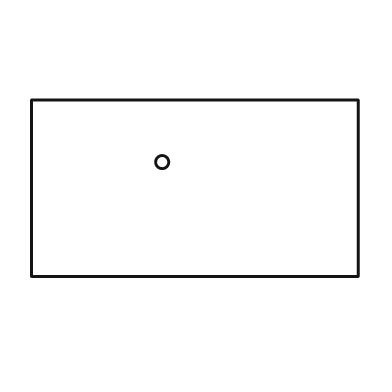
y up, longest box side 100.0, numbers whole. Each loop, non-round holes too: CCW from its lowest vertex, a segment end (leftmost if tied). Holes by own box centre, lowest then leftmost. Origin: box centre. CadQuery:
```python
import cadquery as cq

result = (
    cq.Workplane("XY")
    .moveTo(-50.0, -27.0)
    .lineTo(50.0, -27.0)
    .lineTo(50.0, 27.0)
    .lineTo(-50.0, 27.0)
    .close()
    .moveTo(-10.0, 8.0)
    .circle(2.0)
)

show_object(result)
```